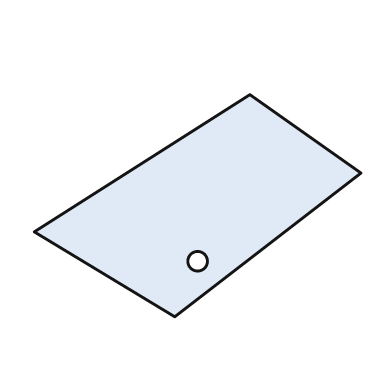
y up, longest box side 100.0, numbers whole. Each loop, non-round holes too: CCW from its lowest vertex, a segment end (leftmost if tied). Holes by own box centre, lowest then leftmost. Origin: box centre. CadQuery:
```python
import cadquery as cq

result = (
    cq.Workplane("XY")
    .moveTo(-7.0, -34.0)
    .lineTo(50.0, 10.0)
    .lineTo(16.0, 34.0)
    .lineTo(-50.0, -8.0)
    .close()
    .moveTo(0.0, -17.0)
    .circle(3.0)
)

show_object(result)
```